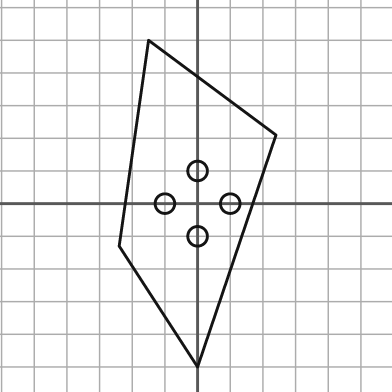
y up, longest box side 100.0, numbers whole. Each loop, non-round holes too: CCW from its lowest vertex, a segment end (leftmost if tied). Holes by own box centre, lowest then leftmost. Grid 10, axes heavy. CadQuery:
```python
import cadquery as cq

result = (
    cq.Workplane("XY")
    .moveTo(0.0, -50.0)
    .lineTo(24.0, 21.0)
    .lineTo(-15.0, 50.0)
    .lineTo(-24.0, -13.0)
    .close()
    .moveTo(0.0, -10.0)
    .circle(3.0)
    .moveTo(-10.0, 0.0)
    .circle(3.0)
    .moveTo(10.0, 0.0)
    .circle(3.0)
    .moveTo(0.0, 10.0)
    .circle(3.0)
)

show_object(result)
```